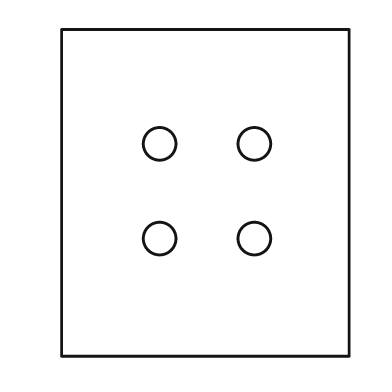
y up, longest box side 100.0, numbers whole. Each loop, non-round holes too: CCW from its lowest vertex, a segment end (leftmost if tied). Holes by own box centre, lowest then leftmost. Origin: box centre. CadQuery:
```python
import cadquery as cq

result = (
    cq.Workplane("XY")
    .moveTo(-44.0, -50.0)
    .lineTo(44.0, -50.0)
    .lineTo(44.0, 50.0)
    .lineTo(-44.0, 50.0)
    .close()
    .moveTo(-14.0, -14.0)
    .circle(5.0)
    .moveTo(15.0, -14.0)
    .circle(5.0)
    .moveTo(-14.0, 15.0)
    .circle(5.0)
    .moveTo(15.0, 15.0)
    .circle(5.0)
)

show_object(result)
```